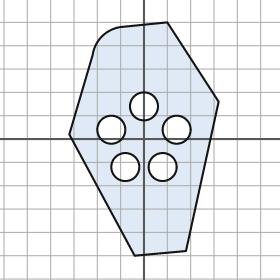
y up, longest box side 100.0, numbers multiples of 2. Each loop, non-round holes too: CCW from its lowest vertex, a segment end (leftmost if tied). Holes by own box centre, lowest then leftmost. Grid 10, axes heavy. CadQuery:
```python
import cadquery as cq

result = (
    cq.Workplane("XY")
    .moveTo(-4.0, -50.0)
    .lineTo(18.0, -48.0)
    .lineTo(32.0, 16.0)
    .lineTo(10.0, 50.0)
    .lineTo(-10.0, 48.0)
    .threePointArc((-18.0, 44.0), (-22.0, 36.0))
    .lineTo(-32.0, 2.0)
    .close()
    .moveTo(-8.0, -12.0)
    .circle(6.0)
    .moveTo(8.0, -12.0)
    .circle(6.0)
    .moveTo(-14.0, 4.0)
    .circle(6.0)
    .moveTo(14.0, 4.0)
    .circle(6.0)
    .moveTo(0.0, 14.0)
    .circle(6.0)
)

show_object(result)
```